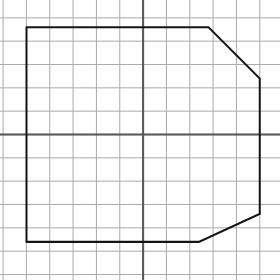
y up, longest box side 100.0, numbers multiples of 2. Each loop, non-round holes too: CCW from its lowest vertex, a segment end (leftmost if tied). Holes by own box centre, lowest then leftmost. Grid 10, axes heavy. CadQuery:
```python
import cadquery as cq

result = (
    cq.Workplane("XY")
    .moveTo(-50.0, -46.0)
    .lineTo(24.0, -46.0)
    .lineTo(50.0, -34.0)
    .lineTo(50.0, 24.0)
    .lineTo(28.0, 46.0)
    .lineTo(-50.0, 46.0)
    .close()
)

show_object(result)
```